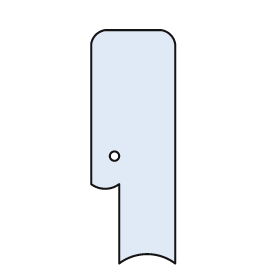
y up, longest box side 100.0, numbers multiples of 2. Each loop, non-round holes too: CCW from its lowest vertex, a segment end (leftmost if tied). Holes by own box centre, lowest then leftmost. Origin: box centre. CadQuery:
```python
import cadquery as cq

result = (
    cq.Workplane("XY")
    .moveTo(-6.0, -50.0)
    .threePointArc((6.0, -46.0), (18.0, -50.0))
    .lineTo(18.0, 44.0)
    .threePointArc((16.0, 48.0), (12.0, 50.0))
    .lineTo(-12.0, 50.0)
    .threePointArc((-16.0, 48.0), (-18.0, 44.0))
    .lineTo(-18.0, -16.0)
    .threePointArc((-12.0, -18.0), (-6.0, -16.0))
    .close()
    .moveTo(-8.0, -4.0)
    .circle(2.0)
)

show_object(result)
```